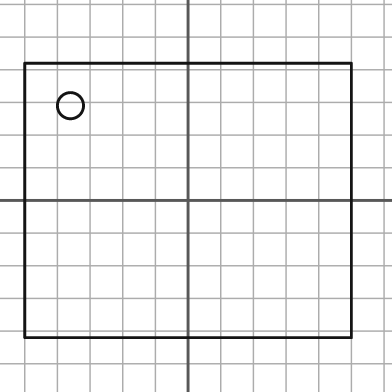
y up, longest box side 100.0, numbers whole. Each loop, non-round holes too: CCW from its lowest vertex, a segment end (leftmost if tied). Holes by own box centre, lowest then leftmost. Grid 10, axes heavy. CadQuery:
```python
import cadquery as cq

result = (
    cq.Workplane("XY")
    .moveTo(-50.0, -42.0)
    .lineTo(50.0, -42.0)
    .lineTo(50.0, 42.0)
    .lineTo(-50.0, 42.0)
    .close()
    .moveTo(-36.0, 29.0)
    .circle(4.0)
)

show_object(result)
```